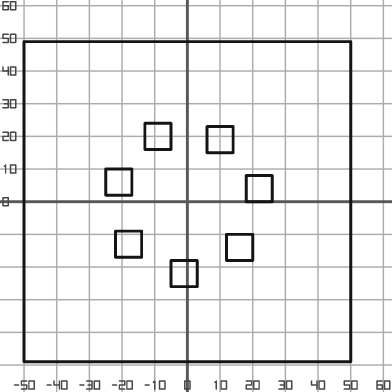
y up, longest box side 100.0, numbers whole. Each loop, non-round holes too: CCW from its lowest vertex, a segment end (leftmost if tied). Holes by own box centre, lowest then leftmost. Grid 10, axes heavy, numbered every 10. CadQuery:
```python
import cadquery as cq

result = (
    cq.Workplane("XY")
    .moveTo(-50.0, -49.0)
    .lineTo(50.0, -49.0)
    .lineTo(50.0, 49.0)
    .lineTo(-50.0, 49.0)
    .close()
    .moveTo(-5.0, -26.0)
    .lineTo(3.0, -26.0)
    .lineTo(3.0, -18.0)
    .lineTo(-5.0, -18.0)
    .close()
    .moveTo(12.0, -18.0)
    .lineTo(20.0, -18.0)
    .lineTo(20.0, -10.0)
    .lineTo(12.0, -10.0)
    .close()
    .moveTo(-22.0, -17.0)
    .lineTo(-14.0, -17.0)
    .lineTo(-14.0, -9.0)
    .lineTo(-22.0, -9.0)
    .close()
    .moveTo(18.0, 0.0)
    .lineTo(26.0, 0.0)
    .lineTo(26.0, 8.0)
    .lineTo(18.0, 8.0)
    .close()
    .moveTo(-25.0, 2.0)
    .lineTo(-17.0, 2.0)
    .lineTo(-17.0, 10.0)
    .lineTo(-25.0, 10.0)
    .close()
    .moveTo(6.0, 15.0)
    .lineTo(14.0, 15.0)
    .lineTo(14.0, 23.0)
    .lineTo(6.0, 23.0)
    .close()
    .moveTo(-13.0, 16.0)
    .lineTo(-5.0, 16.0)
    .lineTo(-5.0, 24.0)
    .lineTo(-13.0, 24.0)
    .close()
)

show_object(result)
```